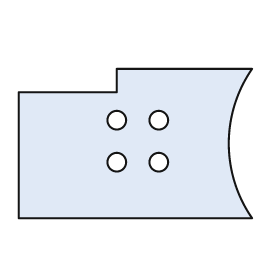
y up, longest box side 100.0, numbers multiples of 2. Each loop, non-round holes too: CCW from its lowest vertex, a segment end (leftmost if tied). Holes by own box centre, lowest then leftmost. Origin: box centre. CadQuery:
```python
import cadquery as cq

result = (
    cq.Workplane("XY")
    .moveTo(-50.0, -32.0)
    .lineTo(50.0, -32.0)
    .threePointArc((40.0, 0.0), (50.0, 32.0))
    .lineTo(-8.0, 32.0)
    .lineTo(-8.0, 22.0)
    .lineTo(-50.0, 22.0)
    .close()
    .moveTo(-8.0, -8.0)
    .circle(4.0)
    .moveTo(10.0, -8.0)
    .circle(4.0)
    .moveTo(-8.0, 10.0)
    .circle(4.0)
    .moveTo(10.0, 10.0)
    .circle(4.0)
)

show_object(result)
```